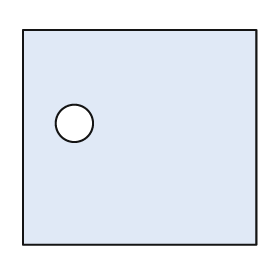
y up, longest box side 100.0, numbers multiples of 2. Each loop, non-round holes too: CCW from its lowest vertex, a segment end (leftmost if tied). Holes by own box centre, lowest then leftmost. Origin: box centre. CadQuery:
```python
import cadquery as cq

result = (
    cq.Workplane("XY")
    .moveTo(-50.0, -46.0)
    .lineTo(50.0, -46.0)
    .lineTo(50.0, 46.0)
    .lineTo(-50.0, 46.0)
    .close()
    .moveTo(-28.0, 6.0)
    .circle(8.0)
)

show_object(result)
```